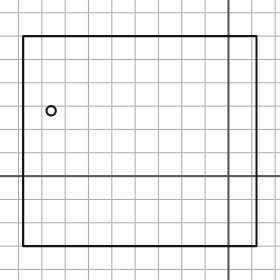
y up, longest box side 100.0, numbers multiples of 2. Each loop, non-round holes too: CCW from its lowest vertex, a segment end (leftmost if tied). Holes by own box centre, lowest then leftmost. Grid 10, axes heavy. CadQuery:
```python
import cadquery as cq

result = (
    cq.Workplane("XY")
    .moveTo(-88.0, -30.0)
    .lineTo(12.0, -30.0)
    .lineTo(12.0, 60.0)
    .lineTo(-88.0, 60.0)
    .close()
    .moveTo(-76.0, 28.0)
    .circle(2.0)
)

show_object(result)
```